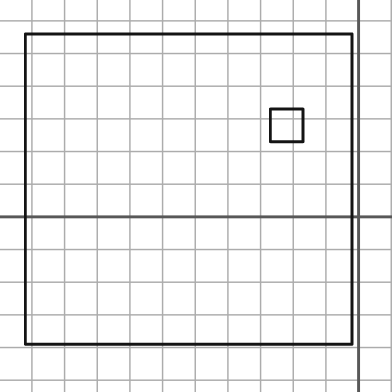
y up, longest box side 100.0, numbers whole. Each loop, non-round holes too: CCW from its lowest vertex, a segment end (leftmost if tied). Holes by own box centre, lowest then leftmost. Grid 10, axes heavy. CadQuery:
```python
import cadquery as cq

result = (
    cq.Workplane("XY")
    .moveTo(-102.0, -39.0)
    .lineTo(-2.0, -39.0)
    .lineTo(-2.0, 56.0)
    .lineTo(-102.0, 56.0)
    .close()
    .moveTo(-27.0, 23.0)
    .lineTo(-17.0, 23.0)
    .lineTo(-17.0, 33.0)
    .lineTo(-27.0, 33.0)
    .close()
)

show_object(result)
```